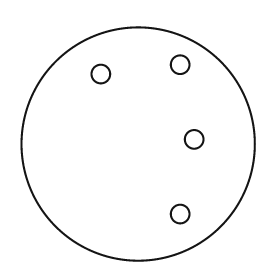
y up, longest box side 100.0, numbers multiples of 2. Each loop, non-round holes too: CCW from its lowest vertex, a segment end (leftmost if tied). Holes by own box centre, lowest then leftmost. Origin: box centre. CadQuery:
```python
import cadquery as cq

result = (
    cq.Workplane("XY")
    .moveTo(0.0, 0.0)
    .circle(50.0)
    .moveTo(18.0, -30.0)
    .circle(4.0)
    .moveTo(24.0, 2.0)
    .circle(4.0)
    .moveTo(-16.0, 30.0)
    .circle(4.0)
    .moveTo(18.0, 34.0)
    .circle(4.0)
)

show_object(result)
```